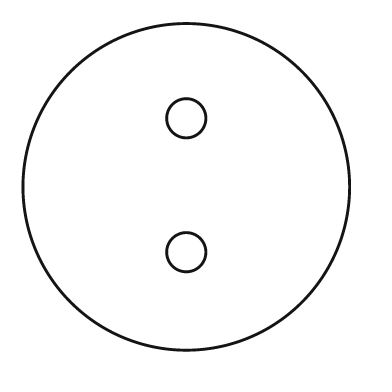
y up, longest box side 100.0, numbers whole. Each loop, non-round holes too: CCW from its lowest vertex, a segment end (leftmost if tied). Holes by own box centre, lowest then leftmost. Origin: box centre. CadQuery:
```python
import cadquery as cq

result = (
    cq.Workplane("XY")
    .moveTo(0.0, 0.0)
    .circle(50.0)
    .moveTo(0.0, -20.0)
    .circle(6.0)
    .moveTo(0.0, 21.0)
    .circle(6.0)
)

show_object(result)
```